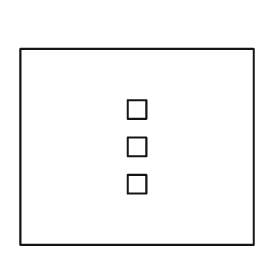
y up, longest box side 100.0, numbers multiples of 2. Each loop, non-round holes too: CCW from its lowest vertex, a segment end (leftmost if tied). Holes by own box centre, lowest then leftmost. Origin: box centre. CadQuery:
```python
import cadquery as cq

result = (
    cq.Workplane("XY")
    .moveTo(-50.0, -42.0)
    .lineTo(50.0, -42.0)
    .lineTo(50.0, 42.0)
    .lineTo(-50.0, 42.0)
    .close()
    .moveTo(-4.0, -20.0)
    .lineTo(4.0, -20.0)
    .lineTo(4.0, -12.0)
    .lineTo(-4.0, -12.0)
    .close()
    .moveTo(-4.0, -4.0)
    .lineTo(4.0, -4.0)
    .lineTo(4.0, 4.0)
    .lineTo(-4.0, 4.0)
    .close()
    .moveTo(-4.0, 12.0)
    .lineTo(4.0, 12.0)
    .lineTo(4.0, 20.0)
    .lineTo(-4.0, 20.0)
    .close()
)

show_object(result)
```